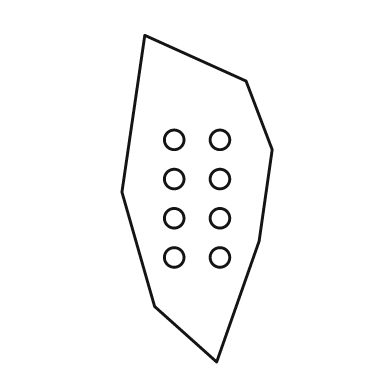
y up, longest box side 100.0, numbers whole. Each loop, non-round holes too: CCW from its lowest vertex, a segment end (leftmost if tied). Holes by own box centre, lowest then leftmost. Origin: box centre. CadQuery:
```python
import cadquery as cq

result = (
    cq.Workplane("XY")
    .moveTo(6.0, -50.0)
    .lineTo(19.0, -13.0)
    .lineTo(23.0, 15.0)
    .lineTo(15.0, 36.0)
    .lineTo(-16.0, 50.0)
    .lineTo(-23.0, 2.0)
    .lineTo(-13.0, -33.0)
    .close()
    .moveTo(-7.0, -18.0)
    .circle(3.0)
    .moveTo(7.0, -18.0)
    .circle(3.0)
    .moveTo(-7.0, -6.0)
    .circle(3.0)
    .moveTo(7.0, -6.0)
    .circle(3.0)
    .moveTo(-7.0, 6.0)
    .circle(3.0)
    .moveTo(7.0, 6.0)
    .circle(3.0)
    .moveTo(-7.0, 18.0)
    .circle(3.0)
    .moveTo(7.0, 18.0)
    .circle(3.0)
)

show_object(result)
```